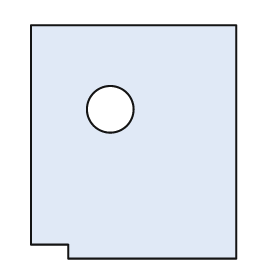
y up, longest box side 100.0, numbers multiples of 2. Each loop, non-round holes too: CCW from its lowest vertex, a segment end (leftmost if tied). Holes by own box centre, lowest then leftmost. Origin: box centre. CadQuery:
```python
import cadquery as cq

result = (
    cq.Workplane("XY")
    .moveTo(-28.0, -50.0)
    .lineTo(44.0, -50.0)
    .lineTo(44.0, 50.0)
    .lineTo(-44.0, 50.0)
    .lineTo(-44.0, -44.0)
    .lineTo(-28.0, -44.0)
    .close()
    .moveTo(-10.0, 14.0)
    .circle(10.0)
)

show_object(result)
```